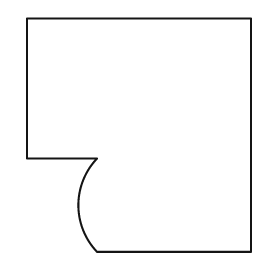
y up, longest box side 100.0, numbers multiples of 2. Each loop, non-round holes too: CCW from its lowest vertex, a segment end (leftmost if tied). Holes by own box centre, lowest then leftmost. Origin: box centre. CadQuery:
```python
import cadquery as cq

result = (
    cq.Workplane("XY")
    .moveTo(-18.0, -50.0)
    .lineTo(48.0, -50.0)
    .lineTo(48.0, 50.0)
    .lineTo(-48.0, 50.0)
    .lineTo(-48.0, -10.0)
    .lineTo(-18.0, -10.0)
    .threePointArc((-26.0, -30.0), (-18.0, -50.0))
    .close()
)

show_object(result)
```